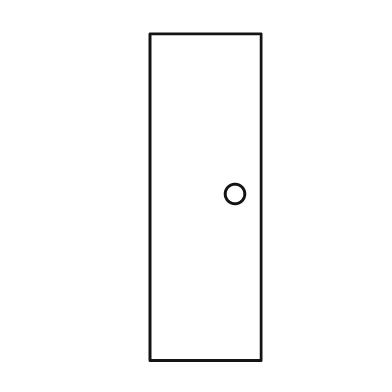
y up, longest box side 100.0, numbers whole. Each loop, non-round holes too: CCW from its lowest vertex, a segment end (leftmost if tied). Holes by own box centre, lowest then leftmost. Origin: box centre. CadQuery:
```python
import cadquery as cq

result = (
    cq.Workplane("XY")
    .moveTo(-17.0, -50.0)
    .lineTo(17.0, -50.0)
    .lineTo(17.0, 50.0)
    .lineTo(-17.0, 50.0)
    .close()
    .moveTo(9.0, 1.0)
    .circle(3.0)
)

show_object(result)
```